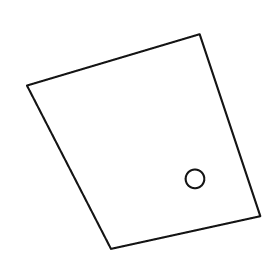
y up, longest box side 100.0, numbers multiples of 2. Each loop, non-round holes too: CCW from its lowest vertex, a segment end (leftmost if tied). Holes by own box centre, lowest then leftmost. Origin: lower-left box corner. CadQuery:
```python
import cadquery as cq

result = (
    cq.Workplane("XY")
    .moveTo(36.0, 0.0)
    .lineTo(100.0, 14.0)
    .lineTo(74.0, 92.0)
    .lineTo(0.0, 70.0)
    .close()
    .moveTo(72.0, 30.0)
    .circle(4.0)
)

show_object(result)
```